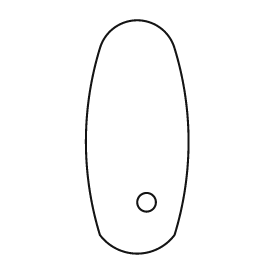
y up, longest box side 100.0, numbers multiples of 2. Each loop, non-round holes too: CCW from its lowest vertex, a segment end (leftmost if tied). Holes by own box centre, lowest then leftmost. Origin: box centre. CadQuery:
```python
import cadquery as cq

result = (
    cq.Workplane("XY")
    .moveTo(-16.0, -42.0)
    .threePointArc((0.0, -50.0), (16.0, -42.0))
    .threePointArc((22.0, -2.0), (16.0, 38.0))
    .threePointArc((0.0, 50.0), (-16.0, 38.0))
    .threePointArc((-22.0, -2.0), (-16.0, -42.0))
    .close()
    .moveTo(4.0, -28.0)
    .circle(4.0)
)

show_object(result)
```